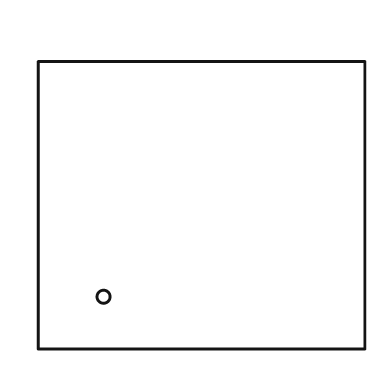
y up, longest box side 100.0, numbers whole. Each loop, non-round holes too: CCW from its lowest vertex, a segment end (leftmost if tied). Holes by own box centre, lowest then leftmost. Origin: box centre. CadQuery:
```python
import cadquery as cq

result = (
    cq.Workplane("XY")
    .moveTo(-50.0, -44.0)
    .lineTo(50.0, -44.0)
    .lineTo(50.0, 44.0)
    .lineTo(-50.0, 44.0)
    .close()
    .moveTo(-30.0, -28.0)
    .circle(2.0)
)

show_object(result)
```